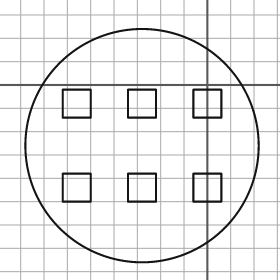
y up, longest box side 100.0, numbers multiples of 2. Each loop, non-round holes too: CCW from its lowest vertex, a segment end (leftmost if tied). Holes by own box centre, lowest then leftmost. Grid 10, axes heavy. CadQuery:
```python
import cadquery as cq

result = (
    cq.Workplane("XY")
    .moveTo(-28.0, -26.0)
    .circle(50.0)
    .moveTo(-62.0, -50.0)
    .lineTo(-50.0, -50.0)
    .lineTo(-50.0, -38.0)
    .lineTo(-62.0, -38.0)
    .close()
    .moveTo(-34.0, -50.0)
    .lineTo(-22.0, -50.0)
    .lineTo(-22.0, -38.0)
    .lineTo(-34.0, -38.0)
    .close()
    .moveTo(-6.0, -50.0)
    .lineTo(6.0, -50.0)
    .lineTo(6.0, -38.0)
    .lineTo(-6.0, -38.0)
    .close()
    .moveTo(-62.0, -14.0)
    .lineTo(-50.0, -14.0)
    .lineTo(-50.0, -2.0)
    .lineTo(-62.0, -2.0)
    .close()
    .moveTo(-34.0, -14.0)
    .lineTo(-22.0, -14.0)
    .lineTo(-22.0, -2.0)
    .lineTo(-34.0, -2.0)
    .close()
    .moveTo(-6.0, -14.0)
    .lineTo(6.0, -14.0)
    .lineTo(6.0, -2.0)
    .lineTo(-6.0, -2.0)
    .close()
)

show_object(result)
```